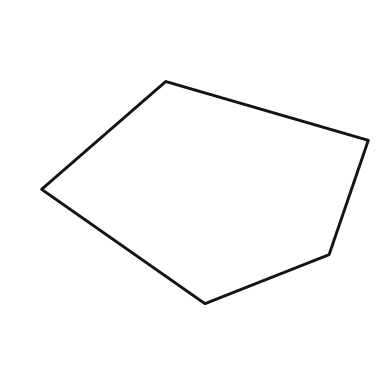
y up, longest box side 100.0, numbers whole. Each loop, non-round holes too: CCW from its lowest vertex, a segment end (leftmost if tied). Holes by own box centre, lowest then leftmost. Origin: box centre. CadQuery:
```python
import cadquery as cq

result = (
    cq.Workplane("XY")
    .moveTo(0.0, -34.0)
    .lineTo(38.0, -19.0)
    .lineTo(50.0, 16.0)
    .lineTo(-12.0, 34.0)
    .lineTo(-50.0, 1.0)
    .close()
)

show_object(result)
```